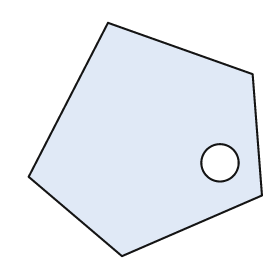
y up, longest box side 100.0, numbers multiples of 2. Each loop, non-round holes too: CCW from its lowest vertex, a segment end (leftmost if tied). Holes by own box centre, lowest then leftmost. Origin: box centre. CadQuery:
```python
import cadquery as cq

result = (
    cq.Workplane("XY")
    .moveTo(-10.0, -50.0)
    .lineTo(50.0, -24.0)
    .lineTo(46.0, 28.0)
    .lineTo(-16.0, 50.0)
    .lineTo(-50.0, -16.0)
    .close()
    .moveTo(32.0, -10.0)
    .circle(8.0)
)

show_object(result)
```